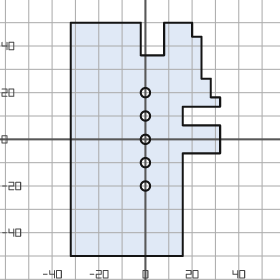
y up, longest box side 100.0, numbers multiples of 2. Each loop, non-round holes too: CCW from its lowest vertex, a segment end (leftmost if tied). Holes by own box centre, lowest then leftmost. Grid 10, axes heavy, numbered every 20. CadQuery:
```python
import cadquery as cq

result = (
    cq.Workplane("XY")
    .moveTo(-32.0, -50.0)
    .lineTo(16.0, -50.0)
    .lineTo(16.0, -6.0)
    .lineTo(32.0, -6.0)
    .lineTo(32.0, 6.0)
    .lineTo(16.0, 6.0)
    .lineTo(16.0, 14.0)
    .lineTo(32.0, 14.0)
    .lineTo(32.0, 18.0)
    .lineTo(28.0, 18.0)
    .lineTo(28.0, 26.0)
    .lineTo(24.0, 26.0)
    .lineTo(24.0, 44.0)
    .lineTo(20.0, 44.0)
    .lineTo(20.0, 50.0)
    .lineTo(8.0, 50.0)
    .lineTo(8.0, 36.0)
    .lineTo(-2.0, 36.0)
    .lineTo(-2.0, 50.0)
    .lineTo(-32.0, 50.0)
    .close()
    .moveTo(0.0, -20.0)
    .circle(2.0)
    .moveTo(0.0, -10.0)
    .circle(2.0)
    .moveTo(0.0, 0.0)
    .circle(2.0)
    .moveTo(0.0, 10.0)
    .circle(2.0)
    .moveTo(0.0, 20.0)
    .circle(2.0)
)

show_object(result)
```